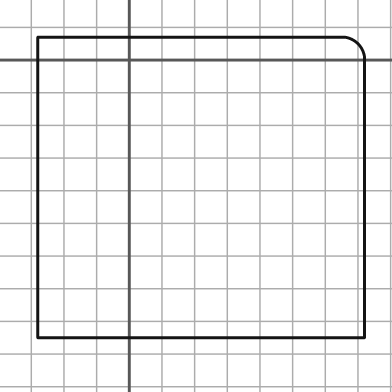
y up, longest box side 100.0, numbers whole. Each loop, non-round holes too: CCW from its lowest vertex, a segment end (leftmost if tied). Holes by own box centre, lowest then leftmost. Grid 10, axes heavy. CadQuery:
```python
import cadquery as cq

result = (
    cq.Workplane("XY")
    .moveTo(-28.0, -85.0)
    .lineTo(72.0, -85.0)
    .lineTo(72.0, 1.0)
    .threePointArc((70.0, 5.0), (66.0, 7.0))
    .lineTo(-28.0, 7.0)
    .close()
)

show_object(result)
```